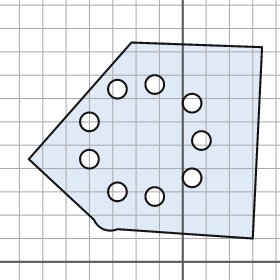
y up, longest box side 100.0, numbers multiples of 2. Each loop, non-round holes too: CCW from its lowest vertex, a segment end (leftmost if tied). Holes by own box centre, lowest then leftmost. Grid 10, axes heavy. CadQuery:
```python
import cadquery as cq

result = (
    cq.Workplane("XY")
    .moveTo(30.0, 10.0)
    .lineTo(34.0, 92.0)
    .lineTo(-22.0, 94.0)
    .lineTo(-66.0, 44.0)
    .lineTo(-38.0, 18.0)
    .threePointArc((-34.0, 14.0), (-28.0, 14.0))
    .close()
    .moveTo(-12.0, 28.0)
    .circle(4.0)
    .moveTo(-28.0, 30.0)
    .circle(4.0)
    .moveTo(4.0, 36.0)
    .circle(4.0)
    .moveTo(-40.0, 44.0)
    .circle(4.0)
    .moveTo(8.0, 52.0)
    .circle(4.0)
    .moveTo(-40.0, 60.0)
    .circle(4.0)
    .moveTo(4.0, 68.0)
    .circle(4.0)
    .moveTo(-28.0, 74.0)
    .circle(4.0)
    .moveTo(-12.0, 76.0)
    .circle(4.0)
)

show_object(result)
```